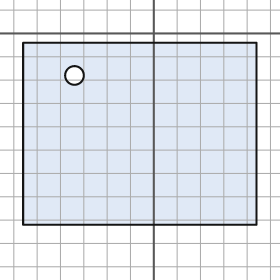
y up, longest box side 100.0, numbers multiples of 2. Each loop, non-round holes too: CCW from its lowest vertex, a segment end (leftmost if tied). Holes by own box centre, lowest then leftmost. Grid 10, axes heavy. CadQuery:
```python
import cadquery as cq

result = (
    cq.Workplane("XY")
    .moveTo(-56.0, -82.0)
    .lineTo(44.0, -82.0)
    .lineTo(44.0, -4.0)
    .lineTo(-56.0, -4.0)
    .close()
    .moveTo(-34.0, -18.0)
    .circle(4.0)
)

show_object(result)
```